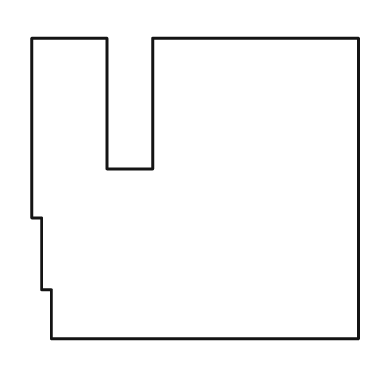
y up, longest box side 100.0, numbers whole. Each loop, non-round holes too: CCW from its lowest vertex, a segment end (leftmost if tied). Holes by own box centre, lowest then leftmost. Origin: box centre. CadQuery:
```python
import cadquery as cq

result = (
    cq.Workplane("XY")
    .moveTo(-44.0, -46.0)
    .lineTo(50.0, -46.0)
    .lineTo(50.0, 46.0)
    .lineTo(-13.0, 46.0)
    .lineTo(-13.0, 6.0)
    .lineTo(-27.0, 6.0)
    .lineTo(-27.0, 46.0)
    .lineTo(-50.0, 46.0)
    .lineTo(-50.0, -9.0)
    .lineTo(-47.0, -9.0)
    .lineTo(-47.0, -31.0)
    .lineTo(-44.0, -31.0)
    .close()
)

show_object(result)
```